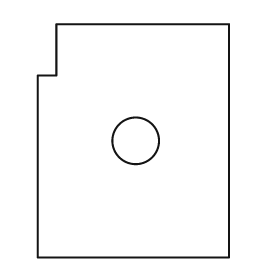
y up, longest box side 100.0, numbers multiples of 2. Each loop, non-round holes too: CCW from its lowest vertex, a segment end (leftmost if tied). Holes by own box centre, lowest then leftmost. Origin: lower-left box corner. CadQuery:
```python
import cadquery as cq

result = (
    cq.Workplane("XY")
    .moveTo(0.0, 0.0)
    .lineTo(82.0, 0.0)
    .lineTo(82.0, 100.0)
    .lineTo(8.0, 100.0)
    .lineTo(8.0, 78.0)
    .lineTo(0.0, 78.0)
    .close()
    .moveTo(42.0, 50.0)
    .circle(10.0)
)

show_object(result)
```